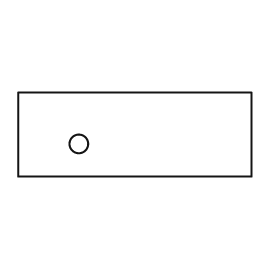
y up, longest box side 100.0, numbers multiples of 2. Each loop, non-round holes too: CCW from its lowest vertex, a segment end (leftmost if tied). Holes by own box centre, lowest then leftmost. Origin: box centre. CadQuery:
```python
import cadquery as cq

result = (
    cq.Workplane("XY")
    .moveTo(-50.0, -18.0)
    .lineTo(50.0, -18.0)
    .lineTo(50.0, 18.0)
    .lineTo(-50.0, 18.0)
    .close()
    .moveTo(-24.0, -4.0)
    .circle(4.0)
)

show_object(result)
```